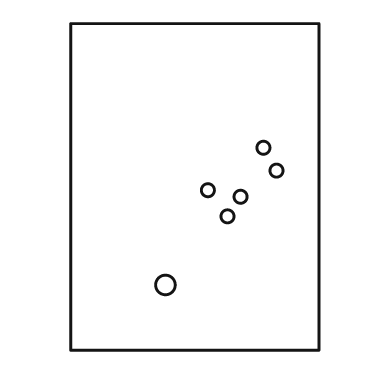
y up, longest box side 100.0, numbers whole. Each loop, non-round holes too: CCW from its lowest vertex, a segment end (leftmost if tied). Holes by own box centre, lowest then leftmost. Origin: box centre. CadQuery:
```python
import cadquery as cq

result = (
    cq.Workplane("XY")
    .moveTo(-38.0, -50.0)
    .lineTo(38.0, -50.0)
    .lineTo(38.0, 50.0)
    .lineTo(-38.0, 50.0)
    .close()
    .moveTo(-9.0, -30.0)
    .circle(3.0)
    .moveTo(10.0, -9.0)
    .circle(2.0)
    .moveTo(14.0, -3.0)
    .circle(2.0)
    .moveTo(4.0, -1.0)
    .circle(2.0)
    .moveTo(25.0, 5.0)
    .circle(2.0)
    .moveTo(21.0, 12.0)
    .circle(2.0)
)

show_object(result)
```